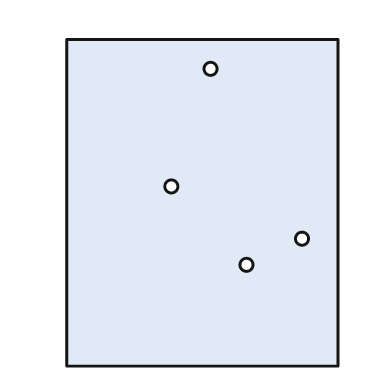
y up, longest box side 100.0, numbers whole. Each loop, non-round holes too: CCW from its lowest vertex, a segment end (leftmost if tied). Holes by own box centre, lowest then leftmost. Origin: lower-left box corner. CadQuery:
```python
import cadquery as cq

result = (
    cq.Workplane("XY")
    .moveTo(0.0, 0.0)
    .lineTo(83.0, 0.0)
    .lineTo(83.0, 100.0)
    .lineTo(0.0, 100.0)
    .close()
    .moveTo(55.0, 31.0)
    .circle(2.0)
    .moveTo(72.0, 39.0)
    .circle(2.0)
    .moveTo(32.0, 55.0)
    .circle(2.0)
    .moveTo(44.0, 91.0)
    .circle(2.0)
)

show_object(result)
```